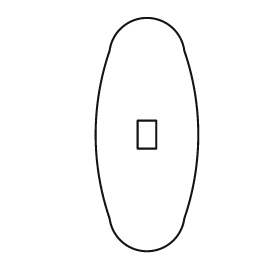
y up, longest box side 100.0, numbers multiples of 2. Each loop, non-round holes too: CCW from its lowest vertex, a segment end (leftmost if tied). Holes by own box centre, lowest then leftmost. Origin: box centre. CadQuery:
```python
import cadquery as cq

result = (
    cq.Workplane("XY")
    .moveTo(-16.0, -36.0)
    .threePointArc((0.0, -50.0), (16.0, -36.0))
    .threePointArc((22.0, 0.0), (16.0, 36.0))
    .threePointArc((0.0, 50.0), (-16.0, 36.0))
    .threePointArc((-22.0, 0.0), (-16.0, -36.0))
    .close()
    .moveTo(-4.0, -6.0)
    .lineTo(4.0, -6.0)
    .lineTo(4.0, 6.0)
    .lineTo(-4.0, 6.0)
    .close()
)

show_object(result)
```